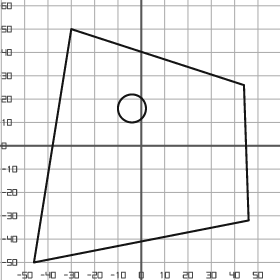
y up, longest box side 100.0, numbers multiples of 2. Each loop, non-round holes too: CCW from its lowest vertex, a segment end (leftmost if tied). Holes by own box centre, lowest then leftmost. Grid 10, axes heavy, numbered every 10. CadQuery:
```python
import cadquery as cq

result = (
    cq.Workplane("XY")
    .moveTo(-46.0, -50.0)
    .lineTo(46.0, -32.0)
    .lineTo(44.0, 26.0)
    .lineTo(-30.0, 50.0)
    .close()
    .moveTo(-4.0, 16.0)
    .circle(6.0)
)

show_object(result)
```